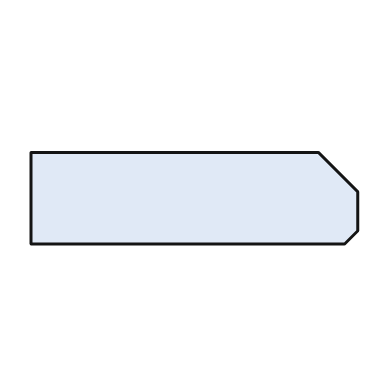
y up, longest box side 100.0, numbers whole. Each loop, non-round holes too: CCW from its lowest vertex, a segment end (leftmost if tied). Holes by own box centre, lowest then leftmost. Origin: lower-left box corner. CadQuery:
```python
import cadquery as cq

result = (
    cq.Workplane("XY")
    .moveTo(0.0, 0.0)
    .lineTo(96.0, 0.0)
    .lineTo(100.0, 4.0)
    .lineTo(100.0, 16.0)
    .lineTo(88.0, 28.0)
    .lineTo(0.0, 28.0)
    .close()
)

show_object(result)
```